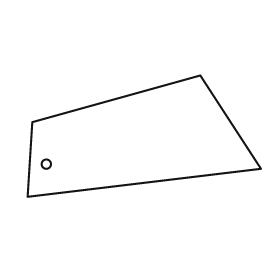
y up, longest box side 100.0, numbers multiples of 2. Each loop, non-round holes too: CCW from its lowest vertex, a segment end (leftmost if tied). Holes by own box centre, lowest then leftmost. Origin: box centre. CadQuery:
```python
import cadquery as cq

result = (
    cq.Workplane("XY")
    .moveTo(-50.0, -26.0)
    .lineTo(50.0, -14.0)
    .lineTo(24.0, 26.0)
    .lineTo(-48.0, 6.0)
    .close()
    .moveTo(-42.0, -12.0)
    .circle(2.0)
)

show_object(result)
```